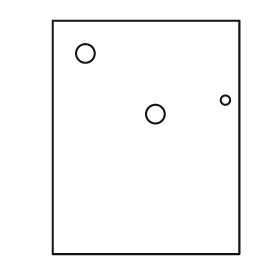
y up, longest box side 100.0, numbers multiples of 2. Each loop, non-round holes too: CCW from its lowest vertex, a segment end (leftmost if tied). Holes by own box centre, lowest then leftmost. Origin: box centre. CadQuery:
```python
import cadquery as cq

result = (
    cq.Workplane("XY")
    .moveTo(-40.0, -50.0)
    .lineTo(40.0, -50.0)
    .lineTo(40.0, 50.0)
    .lineTo(-40.0, 50.0)
    .close()
    .moveTo(4.0, 10.0)
    .circle(4.0)
    .moveTo(34.0, 16.0)
    .circle(2.0)
    .moveTo(-26.0, 36.0)
    .circle(4.0)
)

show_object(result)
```